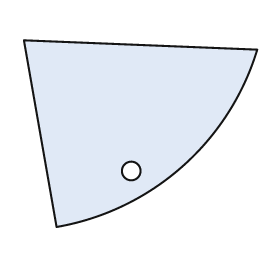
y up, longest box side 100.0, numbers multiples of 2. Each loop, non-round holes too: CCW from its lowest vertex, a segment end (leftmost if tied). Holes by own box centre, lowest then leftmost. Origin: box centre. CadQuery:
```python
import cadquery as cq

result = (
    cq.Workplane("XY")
    .moveTo(-36.0, -40.0)
    .threePointArc((18.0, -14.0), (50.0, 36.0))
    .lineTo(-50.0, 40.0)
    .close()
    .moveTo(-4.0, -16.0)
    .circle(4.0)
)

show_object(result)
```